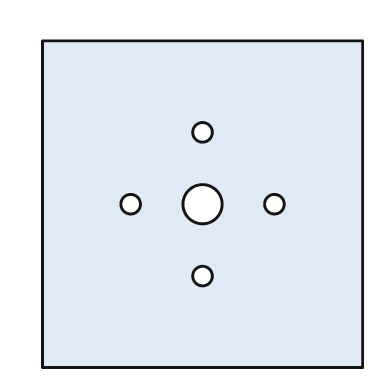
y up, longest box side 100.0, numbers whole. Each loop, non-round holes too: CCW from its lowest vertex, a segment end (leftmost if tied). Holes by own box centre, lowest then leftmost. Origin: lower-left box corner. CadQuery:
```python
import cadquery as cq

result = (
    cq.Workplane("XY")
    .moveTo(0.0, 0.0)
    .lineTo(98.0, 0.0)
    .lineTo(98.0, 100.0)
    .lineTo(0.0, 100.0)
    .close()
    .moveTo(49.0, 28.0)
    .circle(3.0)
    .moveTo(27.0, 50.0)
    .circle(3.0)
    .moveTo(49.0, 50.0)
    .circle(6.0)
    .moveTo(71.0, 50.0)
    .circle(3.0)
    .moveTo(49.0, 72.0)
    .circle(3.0)
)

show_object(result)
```